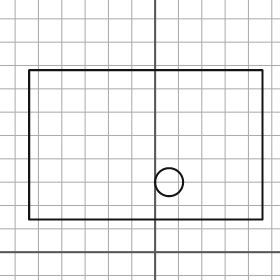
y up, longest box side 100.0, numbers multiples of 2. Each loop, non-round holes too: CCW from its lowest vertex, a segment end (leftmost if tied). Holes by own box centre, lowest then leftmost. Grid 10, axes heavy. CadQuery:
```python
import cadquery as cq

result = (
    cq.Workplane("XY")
    .moveTo(-54.0, 14.0)
    .lineTo(46.0, 14.0)
    .lineTo(46.0, 78.0)
    .lineTo(-54.0, 78.0)
    .close()
    .moveTo(6.0, 30.0)
    .circle(6.0)
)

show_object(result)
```